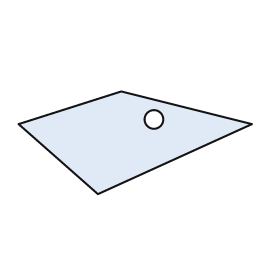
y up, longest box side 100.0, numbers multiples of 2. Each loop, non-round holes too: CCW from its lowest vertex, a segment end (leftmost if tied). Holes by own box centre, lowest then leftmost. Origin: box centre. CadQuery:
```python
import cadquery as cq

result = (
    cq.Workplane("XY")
    .moveTo(-16.0, -22.0)
    .lineTo(50.0, 8.0)
    .lineTo(-6.0, 22.0)
    .lineTo(-50.0, 8.0)
    .close()
    .moveTo(8.0, 10.0)
    .circle(4.0)
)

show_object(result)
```